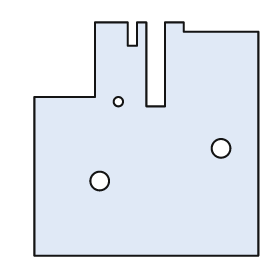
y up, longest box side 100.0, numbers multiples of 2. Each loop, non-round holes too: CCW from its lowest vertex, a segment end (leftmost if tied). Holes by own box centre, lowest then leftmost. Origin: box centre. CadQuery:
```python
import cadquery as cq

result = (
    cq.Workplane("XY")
    .moveTo(-48.0, -50.0)
    .lineTo(48.0, -50.0)
    .lineTo(48.0, 46.0)
    .lineTo(16.0, 46.0)
    .lineTo(16.0, 50.0)
    .lineTo(8.0, 50.0)
    .lineTo(8.0, 14.0)
    .lineTo(0.0, 14.0)
    .lineTo(0.0, 50.0)
    .lineTo(-4.0, 50.0)
    .lineTo(-4.0, 40.0)
    .lineTo(-8.0, 40.0)
    .lineTo(-8.0, 50.0)
    .lineTo(-22.0, 50.0)
    .lineTo(-22.0, 18.0)
    .lineTo(-48.0, 18.0)
    .close()
    .moveTo(-20.0, -18.0)
    .circle(4.0)
    .moveTo(32.0, -4.0)
    .circle(4.0)
    .moveTo(-12.0, 16.0)
    .circle(2.0)
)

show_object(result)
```